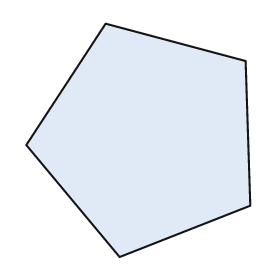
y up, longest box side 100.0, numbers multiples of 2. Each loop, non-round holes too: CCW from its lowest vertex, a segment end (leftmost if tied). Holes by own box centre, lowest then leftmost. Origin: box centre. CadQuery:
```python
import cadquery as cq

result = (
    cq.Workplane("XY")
    .moveTo(-8.0, -50.0)
    .lineTo(48.0, -28.0)
    .lineTo(46.0, 34.0)
    .lineTo(-14.0, 50.0)
    .lineTo(-48.0, -2.0)
    .close()
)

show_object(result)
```